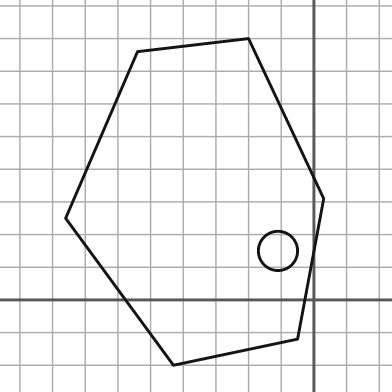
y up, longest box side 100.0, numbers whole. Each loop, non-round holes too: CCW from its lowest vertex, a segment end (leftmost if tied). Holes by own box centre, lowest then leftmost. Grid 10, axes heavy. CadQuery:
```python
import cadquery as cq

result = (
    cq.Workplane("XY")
    .moveTo(-43.0, -20.0)
    .lineTo(-5.0, -12.0)
    .lineTo(3.0, 31.0)
    .lineTo(-20.0, 80.0)
    .lineTo(-54.0, 76.0)
    .lineTo(-76.0, 25.0)
    .close()
    .moveTo(-11.0, 15.0)
    .circle(6.0)
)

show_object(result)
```